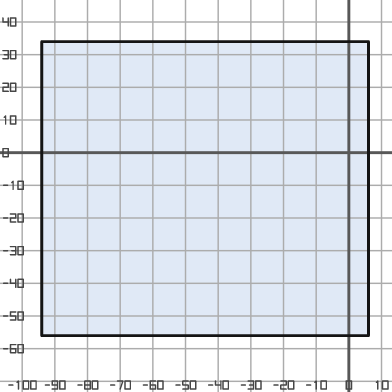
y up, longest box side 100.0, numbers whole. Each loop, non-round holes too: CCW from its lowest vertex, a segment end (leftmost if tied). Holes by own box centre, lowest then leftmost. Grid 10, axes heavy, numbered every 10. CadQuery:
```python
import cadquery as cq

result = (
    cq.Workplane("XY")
    .moveTo(-94.0, -56.0)
    .lineTo(6.0, -56.0)
    .lineTo(6.0, 34.0)
    .lineTo(-94.0, 34.0)
    .close()
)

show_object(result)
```